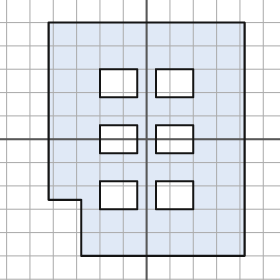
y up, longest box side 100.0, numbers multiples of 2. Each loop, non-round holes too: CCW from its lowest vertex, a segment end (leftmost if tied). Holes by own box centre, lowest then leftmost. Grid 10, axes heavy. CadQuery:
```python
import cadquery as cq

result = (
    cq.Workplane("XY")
    .moveTo(-28.0, -50.0)
    .lineTo(42.0, -50.0)
    .lineTo(42.0, 50.0)
    .lineTo(-42.0, 50.0)
    .lineTo(-42.0, -26.0)
    .lineTo(-28.0, -26.0)
    .close()
    .moveTo(-20.0, -30.0)
    .lineTo(-4.0, -30.0)
    .lineTo(-4.0, -18.0)
    .lineTo(-20.0, -18.0)
    .close()
    .moveTo(4.0, -30.0)
    .lineTo(20.0, -30.0)
    .lineTo(20.0, -18.0)
    .lineTo(4.0, -18.0)
    .close()
    .moveTo(-20.0, -6.0)
    .lineTo(-4.0, -6.0)
    .lineTo(-4.0, 6.0)
    .lineTo(-20.0, 6.0)
    .close()
    .moveTo(4.0, -6.0)
    .lineTo(20.0, -6.0)
    .lineTo(20.0, 6.0)
    .lineTo(4.0, 6.0)
    .close()
    .moveTo(-20.0, 18.0)
    .lineTo(-4.0, 18.0)
    .lineTo(-4.0, 30.0)
    .lineTo(-20.0, 30.0)
    .close()
    .moveTo(4.0, 18.0)
    .lineTo(20.0, 18.0)
    .lineTo(20.0, 30.0)
    .lineTo(4.0, 30.0)
    .close()
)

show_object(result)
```